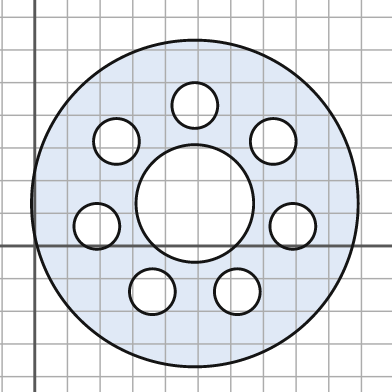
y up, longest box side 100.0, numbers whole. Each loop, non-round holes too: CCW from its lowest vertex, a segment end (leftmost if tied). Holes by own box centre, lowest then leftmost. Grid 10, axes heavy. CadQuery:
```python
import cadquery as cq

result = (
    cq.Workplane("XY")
    .moveTo(49.0, 13.0)
    .circle(50.0)
    .moveTo(36.0, -14.0)
    .circle(7.0)
    .moveTo(62.0, -14.0)
    .circle(7.0)
    .moveTo(19.0, 6.0)
    .circle(7.0)
    .moveTo(79.0, 6.0)
    .circle(7.0)
    .moveTo(49.0, 13.0)
    .circle(18.0)
    .moveTo(25.0, 32.0)
    .circle(7.0)
    .moveTo(73.0, 32.0)
    .circle(7.0)
    .moveTo(49.0, 43.0)
    .circle(7.0)
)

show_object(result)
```